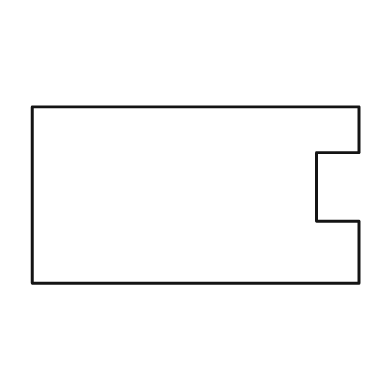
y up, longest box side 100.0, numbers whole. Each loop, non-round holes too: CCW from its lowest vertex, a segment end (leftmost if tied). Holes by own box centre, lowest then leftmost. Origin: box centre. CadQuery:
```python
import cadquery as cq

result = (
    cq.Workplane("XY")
    .moveTo(-50.0, -27.0)
    .lineTo(50.0, -27.0)
    .lineTo(50.0, -8.0)
    .lineTo(37.0, -8.0)
    .lineTo(37.0, 13.0)
    .lineTo(50.0, 13.0)
    .lineTo(50.0, 27.0)
    .lineTo(-50.0, 27.0)
    .close()
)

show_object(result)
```